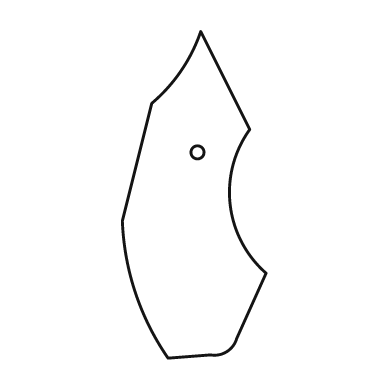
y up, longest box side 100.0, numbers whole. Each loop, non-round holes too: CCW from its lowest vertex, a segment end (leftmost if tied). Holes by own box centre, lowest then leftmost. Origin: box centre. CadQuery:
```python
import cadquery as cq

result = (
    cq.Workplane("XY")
    .moveTo(-8.0, -50.0)
    .lineTo(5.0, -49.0)
    .threePointArc((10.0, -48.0), (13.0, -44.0))
    .lineTo(22.0, -24.0)
    .threePointArc((11.0, -3.0), (17.0, 20.0))
    .lineTo(2.0, 50.0)
    .threePointArc((-4.0, 38.0), (-13.0, 28.0))
    .lineTo(-22.0, -8.0)
    .threePointArc((-18.0, -30.0), (-8.0, -50.0))
    .close()
    .moveTo(1.0, 13.0)
    .circle(2.0)
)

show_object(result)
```